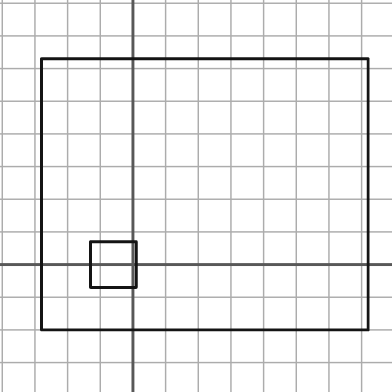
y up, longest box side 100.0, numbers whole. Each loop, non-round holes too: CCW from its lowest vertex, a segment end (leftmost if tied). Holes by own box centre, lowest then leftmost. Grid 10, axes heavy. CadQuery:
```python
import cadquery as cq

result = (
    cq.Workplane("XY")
    .moveTo(-28.0, -20.0)
    .lineTo(72.0, -20.0)
    .lineTo(72.0, 63.0)
    .lineTo(-28.0, 63.0)
    .close()
    .moveTo(-13.0, -7.0)
    .lineTo(1.0, -7.0)
    .lineTo(1.0, 7.0)
    .lineTo(-13.0, 7.0)
    .close()
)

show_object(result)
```